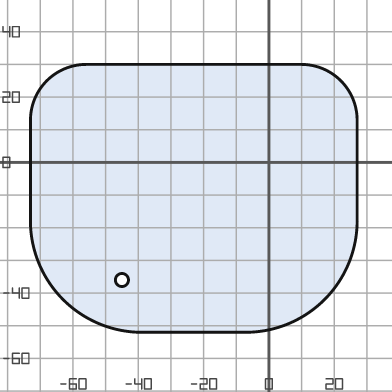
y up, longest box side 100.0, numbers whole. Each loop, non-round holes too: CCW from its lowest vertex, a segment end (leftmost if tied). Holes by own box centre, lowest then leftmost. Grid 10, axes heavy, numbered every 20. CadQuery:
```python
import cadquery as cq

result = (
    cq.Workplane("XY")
    .moveTo(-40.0, -52.0)
    .lineTo(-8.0, -52.0)
    .threePointArc((17.0, -42.0), (27.0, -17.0))
    .lineTo(27.0, 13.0)
    .threePointArc((22.0, 25.0), (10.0, 30.0))
    .lineTo(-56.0, 30.0)
    .threePointArc((-68.0, 25.0), (-73.0, 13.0))
    .lineTo(-73.0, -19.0)
    .threePointArc((-63.0, -42.0), (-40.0, -52.0))
    .close()
    .moveTo(-45.0, -36.0)
    .circle(2.0)
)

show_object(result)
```